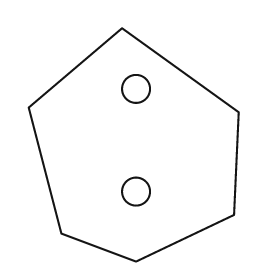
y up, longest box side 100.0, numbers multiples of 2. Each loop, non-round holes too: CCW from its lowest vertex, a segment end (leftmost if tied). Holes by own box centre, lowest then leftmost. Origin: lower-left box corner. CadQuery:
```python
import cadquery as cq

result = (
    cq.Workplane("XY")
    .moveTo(46.0, 0.0)
    .lineTo(88.0, 20.0)
    .lineTo(90.0, 64.0)
    .lineTo(40.0, 100.0)
    .lineTo(0.0, 66.0)
    .lineTo(14.0, 12.0)
    .close()
    .moveTo(46.0, 30.0)
    .circle(6.0)
    .moveTo(46.0, 74.0)
    .circle(6.0)
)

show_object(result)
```